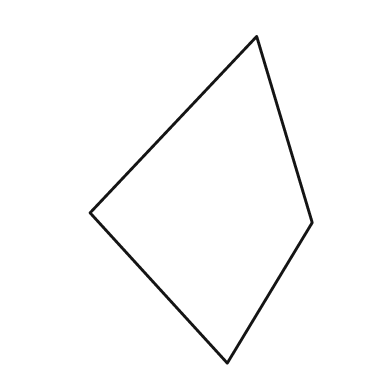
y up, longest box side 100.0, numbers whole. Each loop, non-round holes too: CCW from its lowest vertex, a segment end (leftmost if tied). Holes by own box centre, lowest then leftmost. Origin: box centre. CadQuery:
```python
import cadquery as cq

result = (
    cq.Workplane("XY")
    .moveTo(8.0, -50.0)
    .lineTo(34.0, -7.0)
    .lineTo(17.0, 50.0)
    .lineTo(-34.0, -4.0)
    .close()
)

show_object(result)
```